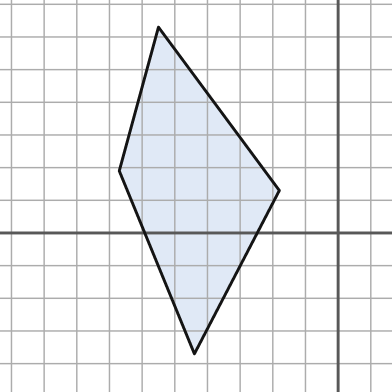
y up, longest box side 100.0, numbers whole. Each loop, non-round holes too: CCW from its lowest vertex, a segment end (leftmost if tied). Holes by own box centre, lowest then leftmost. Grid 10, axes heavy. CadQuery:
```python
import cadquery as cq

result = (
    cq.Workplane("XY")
    .moveTo(-44.0, -37.0)
    .lineTo(-18.0, 13.0)
    .lineTo(-55.0, 63.0)
    .lineTo(-67.0, 19.0)
    .close()
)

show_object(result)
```